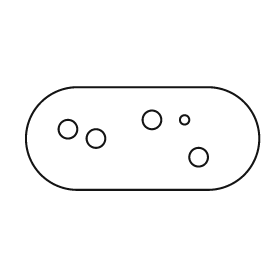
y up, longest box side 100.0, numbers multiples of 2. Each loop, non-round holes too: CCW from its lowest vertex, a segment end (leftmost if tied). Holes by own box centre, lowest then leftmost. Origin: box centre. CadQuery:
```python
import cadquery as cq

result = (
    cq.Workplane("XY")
    .moveTo(-28.0, -22.0)
    .lineTo(28.0, -22.0)
    .threePointArc((50.0, 0.0), (28.0, 22.0))
    .lineTo(-28.0, 22.0)
    .threePointArc((-50.0, 0.0), (-28.0, -22.0))
    .close()
    .moveTo(24.0, -8.0)
    .circle(4.0)
    .moveTo(-20.0, 0.0)
    .circle(4.0)
    .moveTo(-32.0, 4.0)
    .circle(4.0)
    .moveTo(4.0, 8.0)
    .circle(4.0)
    .moveTo(18.0, 8.0)
    .circle(2.0)
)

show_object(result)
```